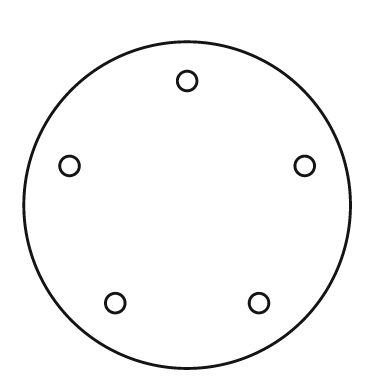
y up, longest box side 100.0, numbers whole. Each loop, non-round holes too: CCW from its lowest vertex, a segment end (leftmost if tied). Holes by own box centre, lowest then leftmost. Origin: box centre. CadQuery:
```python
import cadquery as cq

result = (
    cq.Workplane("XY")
    .moveTo(0.0, 0.0)
    .circle(50.0)
    .moveTo(-22.0, -30.0)
    .circle(3.0)
    .moveTo(22.0, -30.0)
    .circle(3.0)
    .moveTo(-36.0, 12.0)
    .circle(3.0)
    .moveTo(36.0, 12.0)
    .circle(3.0)
    .moveTo(0.0, 38.0)
    .circle(3.0)
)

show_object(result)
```